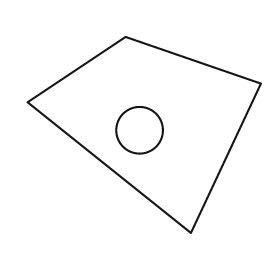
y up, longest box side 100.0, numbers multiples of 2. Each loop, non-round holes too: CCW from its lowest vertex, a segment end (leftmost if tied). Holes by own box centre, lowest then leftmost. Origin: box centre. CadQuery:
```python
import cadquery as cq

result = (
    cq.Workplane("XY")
    .moveTo(20.0, -42.0)
    .lineTo(50.0, 22.0)
    .lineTo(-8.0, 42.0)
    .lineTo(-50.0, 14.0)
    .close()
    .moveTo(-2.0, 2.0)
    .circle(10.0)
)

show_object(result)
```